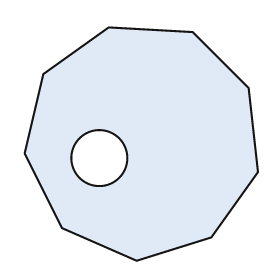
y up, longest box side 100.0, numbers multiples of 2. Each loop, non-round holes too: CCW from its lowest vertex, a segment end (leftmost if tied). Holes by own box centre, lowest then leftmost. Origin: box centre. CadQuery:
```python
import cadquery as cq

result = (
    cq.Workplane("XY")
    .moveTo(-2.0, -50.0)
    .lineTo(30.0, -40.0)
    .lineTo(50.0, -12.0)
    .lineTo(46.0, 24.0)
    .lineTo(22.0, 48.0)
    .lineTo(-14.0, 50.0)
    .lineTo(-42.0, 30.0)
    .lineTo(-50.0, -4.0)
    .lineTo(-34.0, -36.0)
    .close()
    .moveTo(-18.0, -6.0)
    .circle(12.0)
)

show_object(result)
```